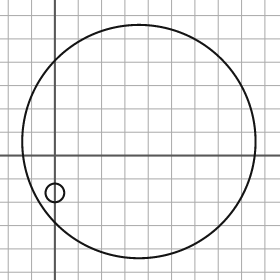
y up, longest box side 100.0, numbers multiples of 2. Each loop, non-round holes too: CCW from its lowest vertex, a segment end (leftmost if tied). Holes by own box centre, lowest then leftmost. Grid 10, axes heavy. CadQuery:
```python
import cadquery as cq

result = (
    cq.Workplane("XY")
    .moveTo(36.0, 6.0)
    .circle(50.0)
    .moveTo(0.0, -16.0)
    .circle(4.0)
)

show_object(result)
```